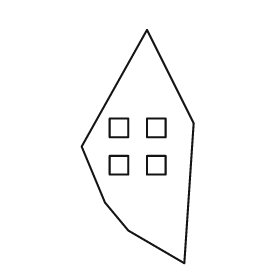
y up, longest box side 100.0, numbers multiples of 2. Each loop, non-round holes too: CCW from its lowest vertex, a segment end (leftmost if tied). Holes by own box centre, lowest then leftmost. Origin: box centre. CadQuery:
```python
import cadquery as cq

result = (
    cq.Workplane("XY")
    .moveTo(20.0, -50.0)
    .lineTo(24.0, 10.0)
    .lineTo(4.0, 50.0)
    .lineTo(-24.0, 0.0)
    .lineTo(-14.0, -24.0)
    .lineTo(-4.0, -36.0)
    .close()
    .moveTo(-12.0, -12.0)
    .lineTo(-4.0, -12.0)
    .lineTo(-4.0, -4.0)
    .lineTo(-12.0, -4.0)
    .close()
    .moveTo(4.0, -12.0)
    .lineTo(12.0, -12.0)
    .lineTo(12.0, -4.0)
    .lineTo(4.0, -4.0)
    .close()
    .moveTo(-12.0, 4.0)
    .lineTo(-4.0, 4.0)
    .lineTo(-4.0, 12.0)
    .lineTo(-12.0, 12.0)
    .close()
    .moveTo(4.0, 4.0)
    .lineTo(12.0, 4.0)
    .lineTo(12.0, 12.0)
    .lineTo(4.0, 12.0)
    .close()
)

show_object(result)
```